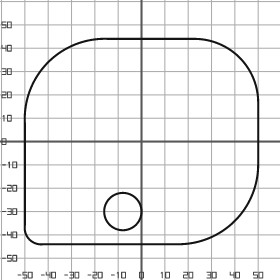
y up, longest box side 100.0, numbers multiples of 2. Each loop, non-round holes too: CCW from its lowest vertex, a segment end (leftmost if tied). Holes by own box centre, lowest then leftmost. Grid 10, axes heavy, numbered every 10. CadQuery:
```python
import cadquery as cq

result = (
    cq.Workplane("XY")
    .moveTo(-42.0, -44.0)
    .lineTo(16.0, -44.0)
    .threePointArc((40.0, -34.0), (50.0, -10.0))
    .lineTo(50.0, 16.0)
    .threePointArc((42.0, 36.0), (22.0, 44.0))
    .lineTo(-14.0, 44.0)
    .threePointArc((-40.0, 34.0), (-50.0, 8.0))
    .lineTo(-50.0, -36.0)
    .threePointArc((-48.0, -42.0), (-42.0, -44.0))
    .close()
    .moveTo(-8.0, -30.0)
    .circle(8.0)
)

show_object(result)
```